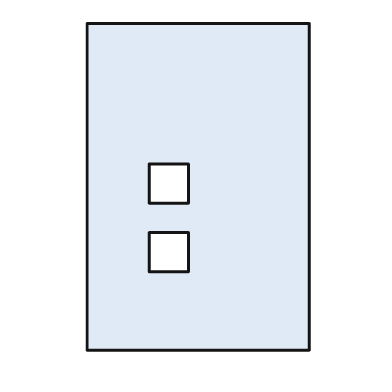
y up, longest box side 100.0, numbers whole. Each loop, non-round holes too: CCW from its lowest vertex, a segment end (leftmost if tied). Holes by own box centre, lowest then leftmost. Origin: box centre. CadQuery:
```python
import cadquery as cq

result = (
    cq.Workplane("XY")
    .moveTo(-34.0, -50.0)
    .lineTo(34.0, -50.0)
    .lineTo(34.0, 50.0)
    .lineTo(-34.0, 50.0)
    .close()
    .moveTo(-15.0, -26.0)
    .lineTo(-3.0, -26.0)
    .lineTo(-3.0, -14.0)
    .lineTo(-15.0, -14.0)
    .close()
    .moveTo(-15.0, -5.0)
    .lineTo(-3.0, -5.0)
    .lineTo(-3.0, 7.0)
    .lineTo(-15.0, 7.0)
    .close()
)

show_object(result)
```